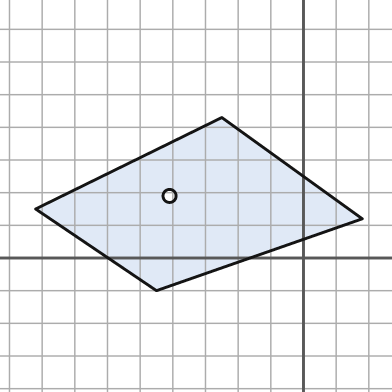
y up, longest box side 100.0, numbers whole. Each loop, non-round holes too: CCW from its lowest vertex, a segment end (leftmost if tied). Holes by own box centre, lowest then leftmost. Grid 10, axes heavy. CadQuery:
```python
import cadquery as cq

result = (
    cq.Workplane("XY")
    .moveTo(-45.0, -10.0)
    .lineTo(18.0, 12.0)
    .lineTo(-25.0, 43.0)
    .lineTo(-82.0, 15.0)
    .close()
    .moveTo(-41.0, 19.0)
    .circle(2.0)
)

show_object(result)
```